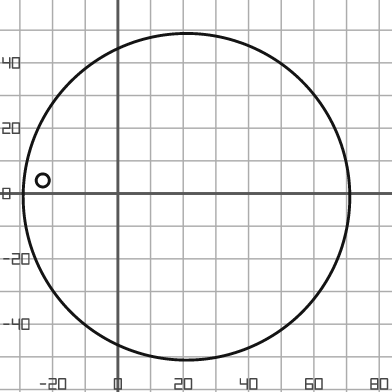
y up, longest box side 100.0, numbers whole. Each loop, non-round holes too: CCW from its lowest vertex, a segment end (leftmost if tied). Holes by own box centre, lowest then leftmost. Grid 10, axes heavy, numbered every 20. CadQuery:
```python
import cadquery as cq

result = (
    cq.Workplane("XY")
    .moveTo(21.0, -1.0)
    .circle(50.0)
    .moveTo(-23.0, 4.0)
    .circle(2.0)
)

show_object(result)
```